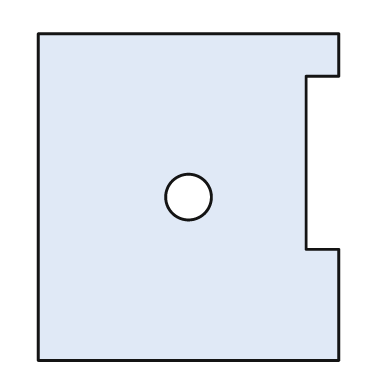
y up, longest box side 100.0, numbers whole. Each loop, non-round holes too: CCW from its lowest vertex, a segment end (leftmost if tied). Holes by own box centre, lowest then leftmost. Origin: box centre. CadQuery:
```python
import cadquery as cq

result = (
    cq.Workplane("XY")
    .moveTo(-46.0, -50.0)
    .lineTo(46.0, -50.0)
    .lineTo(46.0, -16.0)
    .lineTo(36.0, -16.0)
    .lineTo(36.0, 37.0)
    .lineTo(46.0, 37.0)
    .lineTo(46.0, 50.0)
    .lineTo(-46.0, 50.0)
    .close()
    .moveTo(0.0, 0.0)
    .circle(7.0)
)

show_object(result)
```